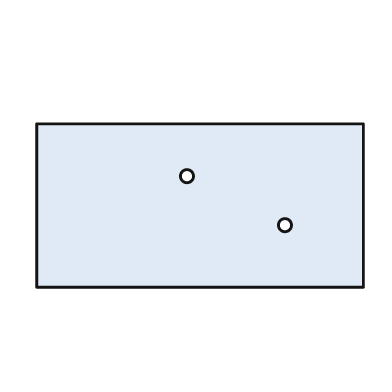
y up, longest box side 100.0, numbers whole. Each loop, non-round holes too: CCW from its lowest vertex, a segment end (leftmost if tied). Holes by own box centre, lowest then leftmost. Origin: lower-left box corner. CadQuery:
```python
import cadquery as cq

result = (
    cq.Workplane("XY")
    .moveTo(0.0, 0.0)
    .lineTo(100.0, 0.0)
    .lineTo(100.0, 50.0)
    .lineTo(0.0, 50.0)
    .close()
    .moveTo(76.0, 19.0)
    .circle(2.0)
    .moveTo(46.0, 34.0)
    .circle(2.0)
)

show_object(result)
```